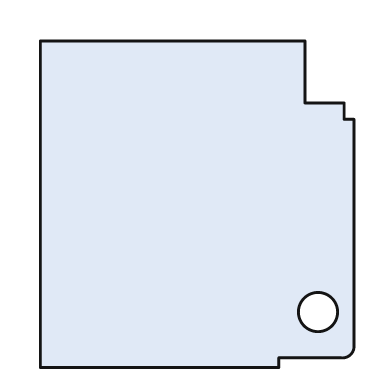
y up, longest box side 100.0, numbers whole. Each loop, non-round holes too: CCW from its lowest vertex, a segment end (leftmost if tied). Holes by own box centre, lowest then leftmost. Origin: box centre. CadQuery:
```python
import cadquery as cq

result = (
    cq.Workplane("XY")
    .moveTo(-48.0, -50.0)
    .lineTo(25.0, -50.0)
    .lineTo(25.0, -47.0)
    .lineTo(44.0, -47.0)
    .threePointArc((47.0, -46.0), (48.0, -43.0))
    .lineTo(48.0, 26.0)
    .lineTo(45.0, 26.0)
    .lineTo(45.0, 31.0)
    .lineTo(33.0, 31.0)
    .lineTo(33.0, 50.0)
    .lineTo(-48.0, 50.0)
    .close()
    .moveTo(37.0, -33.0)
    .circle(6.0)
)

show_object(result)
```